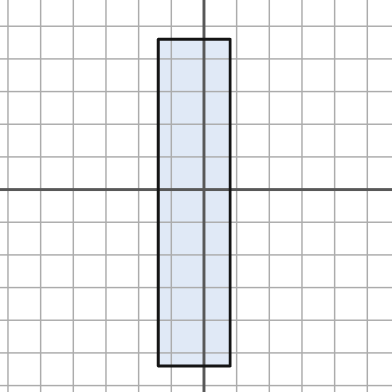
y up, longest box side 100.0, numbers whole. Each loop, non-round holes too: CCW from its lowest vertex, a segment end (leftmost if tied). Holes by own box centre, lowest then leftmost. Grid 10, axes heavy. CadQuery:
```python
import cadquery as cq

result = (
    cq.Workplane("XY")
    .moveTo(-14.0, -54.0)
    .lineTo(8.0, -54.0)
    .lineTo(8.0, 46.0)
    .lineTo(-14.0, 46.0)
    .close()
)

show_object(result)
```